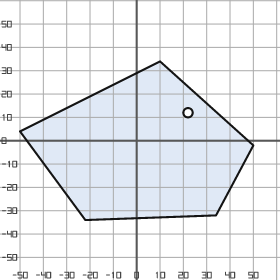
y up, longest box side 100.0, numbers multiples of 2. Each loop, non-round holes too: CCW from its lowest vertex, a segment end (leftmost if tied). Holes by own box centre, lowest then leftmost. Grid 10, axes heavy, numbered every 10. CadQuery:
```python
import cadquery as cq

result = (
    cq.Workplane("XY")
    .moveTo(-22.0, -34.0)
    .lineTo(34.0, -32.0)
    .lineTo(50.0, -2.0)
    .lineTo(10.0, 34.0)
    .lineTo(-50.0, 4.0)
    .close()
    .moveTo(22.0, 12.0)
    .circle(2.0)
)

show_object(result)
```